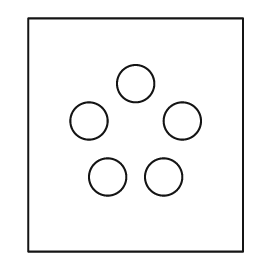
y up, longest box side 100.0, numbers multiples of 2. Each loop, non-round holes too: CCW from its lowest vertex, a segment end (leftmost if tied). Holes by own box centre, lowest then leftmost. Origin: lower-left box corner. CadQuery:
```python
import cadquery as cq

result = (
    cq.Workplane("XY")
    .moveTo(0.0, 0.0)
    .lineTo(92.0, 0.0)
    .lineTo(92.0, 100.0)
    .lineTo(0.0, 100.0)
    .close()
    .moveTo(34.0, 32.0)
    .circle(8.0)
    .moveTo(58.0, 32.0)
    .circle(8.0)
    .moveTo(26.0, 56.0)
    .circle(8.0)
    .moveTo(66.0, 56.0)
    .circle(8.0)
    .moveTo(46.0, 72.0)
    .circle(8.0)
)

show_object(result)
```